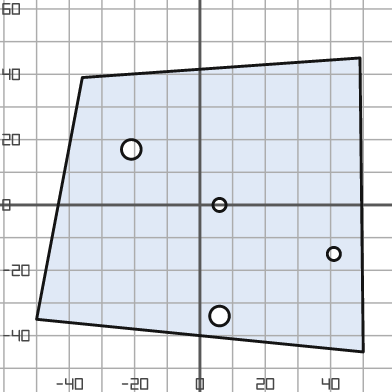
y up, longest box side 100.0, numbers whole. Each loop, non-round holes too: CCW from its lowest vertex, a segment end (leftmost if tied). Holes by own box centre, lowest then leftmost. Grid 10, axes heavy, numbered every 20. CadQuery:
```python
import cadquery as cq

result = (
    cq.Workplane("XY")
    .moveTo(50.0, -45.0)
    .lineTo(49.0, 45.0)
    .lineTo(-36.0, 39.0)
    .lineTo(-50.0, -35.0)
    .close()
    .moveTo(6.0, -34.0)
    .circle(3.0)
    .moveTo(41.0, -15.0)
    .circle(2.0)
    .moveTo(6.0, 0.0)
    .circle(2.0)
    .moveTo(-21.0, 17.0)
    .circle(3.0)
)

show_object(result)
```